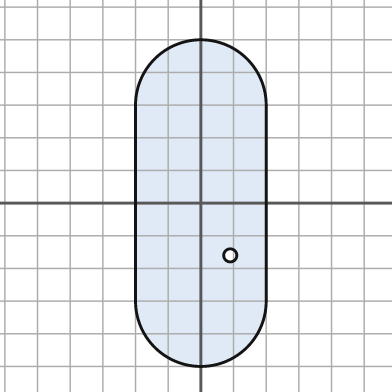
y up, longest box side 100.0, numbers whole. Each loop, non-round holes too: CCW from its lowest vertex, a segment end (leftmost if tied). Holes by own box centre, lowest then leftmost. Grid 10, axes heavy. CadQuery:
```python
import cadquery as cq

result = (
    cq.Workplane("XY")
    .moveTo(-20.0, -30.0)
    .threePointArc((0.0, -50.0), (20.0, -30.0))
    .lineTo(20.0, 30.0)
    .threePointArc((0.0, 50.0), (-20.0, 30.0))
    .close()
    .moveTo(9.0, -16.0)
    .circle(2.0)
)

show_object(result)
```